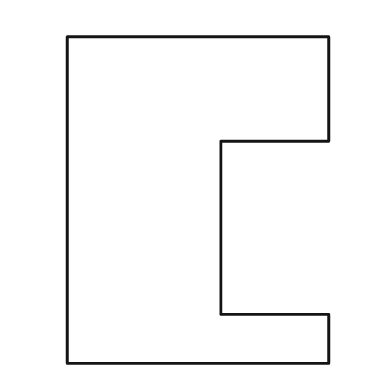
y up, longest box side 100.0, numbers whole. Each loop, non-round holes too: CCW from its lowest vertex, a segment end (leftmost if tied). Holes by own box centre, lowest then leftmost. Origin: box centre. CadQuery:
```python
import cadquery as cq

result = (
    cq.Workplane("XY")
    .moveTo(-40.0, -50.0)
    .lineTo(40.0, -50.0)
    .lineTo(40.0, -35.0)
    .lineTo(7.0, -35.0)
    .lineTo(7.0, 18.0)
    .lineTo(40.0, 18.0)
    .lineTo(40.0, 50.0)
    .lineTo(-40.0, 50.0)
    .close()
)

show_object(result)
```